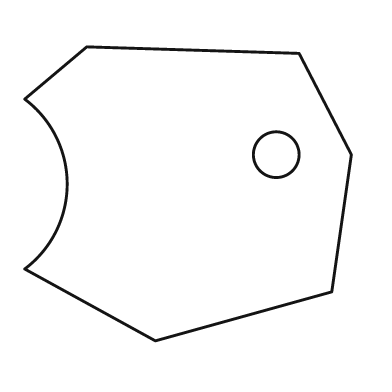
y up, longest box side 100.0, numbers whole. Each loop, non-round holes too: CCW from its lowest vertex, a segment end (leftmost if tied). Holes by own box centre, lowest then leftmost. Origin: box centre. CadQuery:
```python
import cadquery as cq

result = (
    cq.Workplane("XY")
    .moveTo(-10.0, -45.0)
    .lineTo(44.0, -30.0)
    .lineTo(50.0, 12.0)
    .lineTo(34.0, 43.0)
    .lineTo(-31.0, 45.0)
    .lineTo(-50.0, 29.0)
    .threePointArc((-37.0, 3.0), (-50.0, -23.0))
    .close()
    .moveTo(27.0, 12.0)
    .circle(7.0)
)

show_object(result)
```